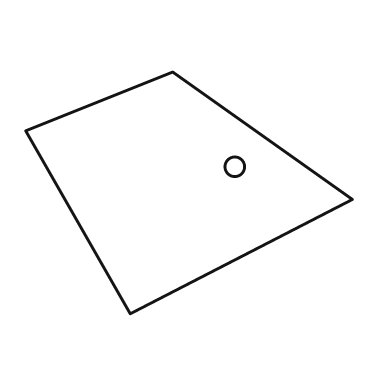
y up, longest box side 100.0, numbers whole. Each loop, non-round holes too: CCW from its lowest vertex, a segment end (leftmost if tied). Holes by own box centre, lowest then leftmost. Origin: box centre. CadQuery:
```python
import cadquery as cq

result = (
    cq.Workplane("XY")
    .moveTo(-18.0, -37.0)
    .lineTo(50.0, -2.0)
    .lineTo(-5.0, 37.0)
    .lineTo(-50.0, 19.0)
    .close()
    .moveTo(14.0, 8.0)
    .circle(3.0)
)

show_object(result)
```